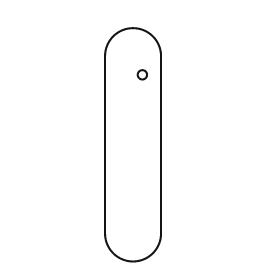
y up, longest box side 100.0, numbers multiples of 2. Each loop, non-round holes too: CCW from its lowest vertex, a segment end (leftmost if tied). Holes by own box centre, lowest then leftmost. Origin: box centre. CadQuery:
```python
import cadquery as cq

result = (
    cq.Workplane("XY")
    .moveTo(-12.0, -38.0)
    .threePointArc((0.0, -50.0), (12.0, -38.0))
    .lineTo(12.0, 38.0)
    .threePointArc((0.0, 50.0), (-12.0, 38.0))
    .close()
    .moveTo(4.0, 30.0)
    .circle(2.0)
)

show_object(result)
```